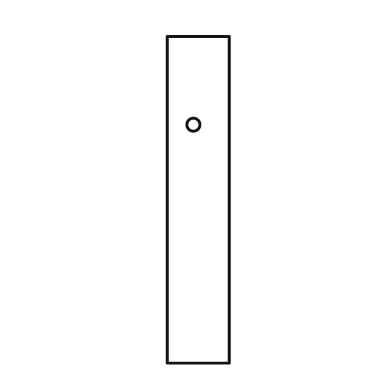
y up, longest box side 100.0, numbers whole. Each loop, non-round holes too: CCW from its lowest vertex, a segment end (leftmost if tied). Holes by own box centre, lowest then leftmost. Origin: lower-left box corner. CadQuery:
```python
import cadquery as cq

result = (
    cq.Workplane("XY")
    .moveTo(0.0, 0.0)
    .lineTo(19.0, 0.0)
    .lineTo(19.0, 100.0)
    .lineTo(0.0, 100.0)
    .close()
    .moveTo(8.0, 73.0)
    .circle(2.0)
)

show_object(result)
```